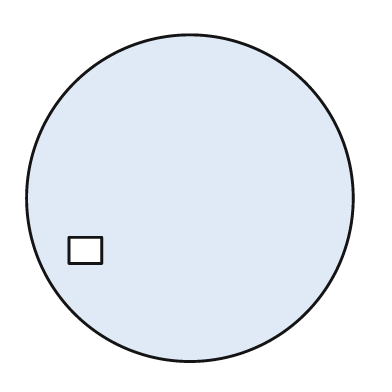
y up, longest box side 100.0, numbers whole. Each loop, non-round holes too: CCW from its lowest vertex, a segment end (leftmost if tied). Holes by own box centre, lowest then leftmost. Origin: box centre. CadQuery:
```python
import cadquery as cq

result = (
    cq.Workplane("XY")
    .moveTo(0.0, 0.0)
    .circle(50.0)
    .moveTo(-37.0, -20.0)
    .lineTo(-27.0, -20.0)
    .lineTo(-27.0, -12.0)
    .lineTo(-37.0, -12.0)
    .close()
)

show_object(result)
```